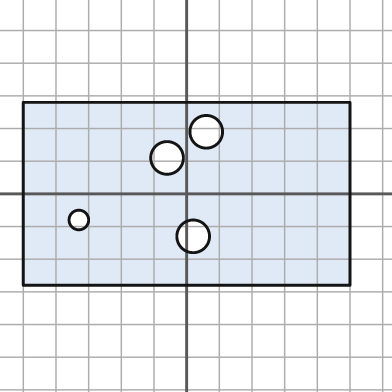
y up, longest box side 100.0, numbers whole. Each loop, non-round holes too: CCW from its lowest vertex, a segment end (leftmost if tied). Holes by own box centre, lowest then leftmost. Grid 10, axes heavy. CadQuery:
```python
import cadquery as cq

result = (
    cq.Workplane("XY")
    .moveTo(-50.0, -28.0)
    .lineTo(50.0, -28.0)
    .lineTo(50.0, 28.0)
    .lineTo(-50.0, 28.0)
    .close()
    .moveTo(2.0, -13.0)
    .circle(5.0)
    .moveTo(-33.0, -8.0)
    .circle(3.0)
    .moveTo(-6.0, 11.0)
    .circle(5.0)
    .moveTo(6.0, 19.0)
    .circle(5.0)
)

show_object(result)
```